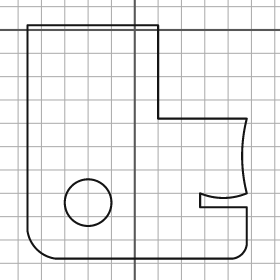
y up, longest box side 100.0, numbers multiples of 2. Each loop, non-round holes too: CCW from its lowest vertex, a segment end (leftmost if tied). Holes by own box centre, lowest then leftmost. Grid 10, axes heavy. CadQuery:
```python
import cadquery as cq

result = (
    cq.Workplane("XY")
    .moveTo(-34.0, -98.0)
    .lineTo(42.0, -98.0)
    .threePointArc((46.0, -96.0), (48.0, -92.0))
    .lineTo(48.0, -76.0)
    .lineTo(28.0, -76.0)
    .lineTo(28.0, -70.0)
    .threePointArc((38.0, -72.0), (48.0, -70.0))
    .threePointArc((46.0, -54.0), (48.0, -38.0))
    .lineTo(10.0, -38.0)
    .lineTo(10.0, 2.0)
    .lineTo(-46.0, 2.0)
    .lineTo(-46.0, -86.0)
    .threePointArc((-42.0, -94.0), (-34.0, -98.0))
    .close()
    .moveTo(-20.0, -74.0)
    .circle(10.0)
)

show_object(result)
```